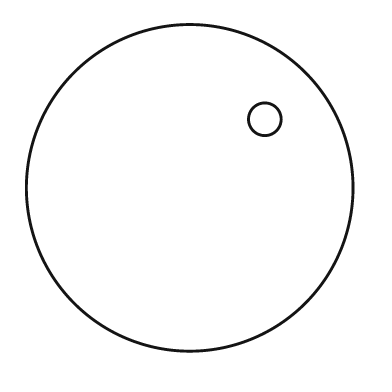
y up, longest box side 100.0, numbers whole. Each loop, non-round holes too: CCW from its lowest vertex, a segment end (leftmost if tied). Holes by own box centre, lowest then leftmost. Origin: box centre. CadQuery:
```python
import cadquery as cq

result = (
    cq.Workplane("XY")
    .moveTo(0.0, 0.0)
    .circle(50.0)
    .moveTo(23.0, 21.0)
    .circle(5.0)
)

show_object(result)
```